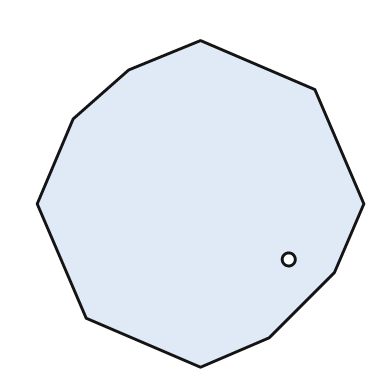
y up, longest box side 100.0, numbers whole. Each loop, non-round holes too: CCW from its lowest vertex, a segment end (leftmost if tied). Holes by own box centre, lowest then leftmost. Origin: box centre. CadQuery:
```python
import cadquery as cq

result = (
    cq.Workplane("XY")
    .moveTo(0.0, -50.0)
    .lineTo(21.0, -41.0)
    .lineTo(41.0, -21.0)
    .lineTo(50.0, 0.0)
    .lineTo(35.0, 35.0)
    .lineTo(0.0, 50.0)
    .lineTo(-22.0, 41.0)
    .lineTo(-39.0, 26.0)
    .lineTo(-50.0, 0.0)
    .lineTo(-35.0, -35.0)
    .close()
    .moveTo(27.0, -17.0)
    .circle(2.0)
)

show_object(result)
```